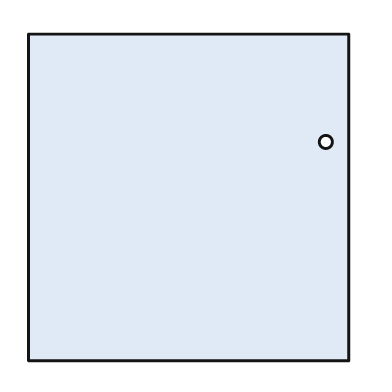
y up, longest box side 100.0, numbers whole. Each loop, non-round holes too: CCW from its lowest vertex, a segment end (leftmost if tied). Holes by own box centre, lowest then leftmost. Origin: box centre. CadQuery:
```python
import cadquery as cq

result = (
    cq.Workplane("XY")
    .moveTo(-49.0, -50.0)
    .lineTo(49.0, -50.0)
    .lineTo(49.0, 50.0)
    .lineTo(-49.0, 50.0)
    .close()
    .moveTo(42.0, 17.0)
    .circle(2.0)
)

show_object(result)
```